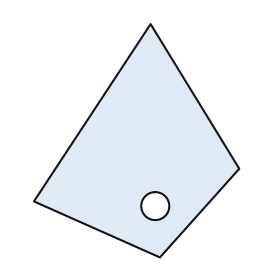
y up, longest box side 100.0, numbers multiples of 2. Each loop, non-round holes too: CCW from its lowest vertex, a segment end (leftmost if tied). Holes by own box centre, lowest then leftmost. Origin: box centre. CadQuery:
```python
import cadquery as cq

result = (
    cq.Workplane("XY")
    .moveTo(10.0, -50.0)
    .lineTo(44.0, -12.0)
    .lineTo(6.0, 50.0)
    .lineTo(-44.0, -26.0)
    .close()
    .moveTo(8.0, -28.0)
    .circle(6.0)
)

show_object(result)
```